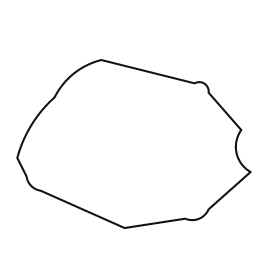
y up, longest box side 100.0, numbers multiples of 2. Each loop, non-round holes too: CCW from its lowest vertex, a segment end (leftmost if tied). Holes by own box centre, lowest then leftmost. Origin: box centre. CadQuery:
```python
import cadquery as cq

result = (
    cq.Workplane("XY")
    .moveTo(-4.0, -36.0)
    .lineTo(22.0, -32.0)
    .threePointArc((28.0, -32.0), (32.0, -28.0))
    .lineTo(50.0, -12.0)
    .threePointArc((44.0, -4.0), (46.0, 6.0))
    .lineTo(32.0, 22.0)
    .threePointArc((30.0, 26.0), (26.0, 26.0))
    .lineTo(-14.0, 36.0)
    .threePointArc((-26.0, 30.0), (-34.0, 20.0))
    .threePointArc((-44.0, 8.0), (-50.0, -6.0))
    .lineTo(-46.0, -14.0)
    .threePointArc((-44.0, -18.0), (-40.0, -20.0))
    .close()
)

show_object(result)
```